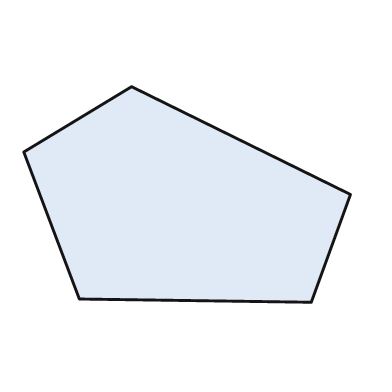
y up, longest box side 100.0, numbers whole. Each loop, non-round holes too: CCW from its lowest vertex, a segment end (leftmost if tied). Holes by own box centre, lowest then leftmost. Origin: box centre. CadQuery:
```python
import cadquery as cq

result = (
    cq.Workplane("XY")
    .moveTo(38.0, -33.0)
    .lineTo(50.0, 0.0)
    .lineTo(-17.0, 33.0)
    .lineTo(-50.0, 13.0)
    .lineTo(-33.0, -32.0)
    .close()
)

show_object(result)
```